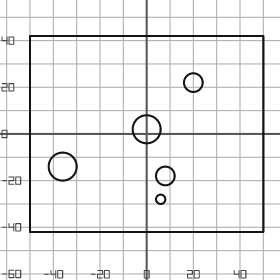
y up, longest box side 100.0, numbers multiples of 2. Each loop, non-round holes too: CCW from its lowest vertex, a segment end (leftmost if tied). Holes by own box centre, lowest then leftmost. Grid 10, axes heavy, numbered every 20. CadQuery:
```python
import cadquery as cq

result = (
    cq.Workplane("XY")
    .moveTo(-50.0, -42.0)
    .lineTo(50.0, -42.0)
    .lineTo(50.0, 42.0)
    .lineTo(-50.0, 42.0)
    .close()
    .moveTo(6.0, -28.0)
    .circle(2.0)
    .moveTo(8.0, -18.0)
    .circle(4.0)
    .moveTo(-36.0, -14.0)
    .circle(6.0)
    .moveTo(0.0, 2.0)
    .circle(6.0)
    .moveTo(20.0, 22.0)
    .circle(4.0)
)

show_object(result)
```